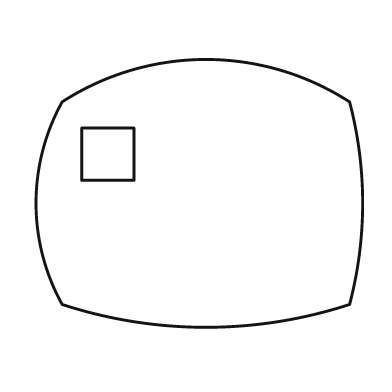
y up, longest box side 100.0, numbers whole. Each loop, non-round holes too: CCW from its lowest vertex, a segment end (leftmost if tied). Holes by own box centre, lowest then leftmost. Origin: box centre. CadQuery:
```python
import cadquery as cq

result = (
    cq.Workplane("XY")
    .moveTo(-42.0, -34.0)
    .threePointArc((2.0, -41.0), (46.0, -34.0))
    .threePointArc((50.0, -3.0), (46.0, 28.0))
    .threePointArc((2.0, 41.0), (-42.0, 28.0))
    .threePointArc((-50.0, -3.0), (-42.0, -34.0))
    .close()
    .moveTo(-36.0, 4.0)
    .lineTo(-20.0, 4.0)
    .lineTo(-20.0, 20.0)
    .lineTo(-36.0, 20.0)
    .close()
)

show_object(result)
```